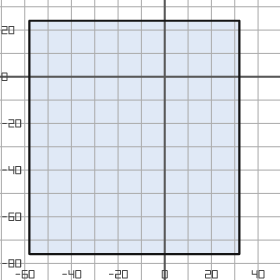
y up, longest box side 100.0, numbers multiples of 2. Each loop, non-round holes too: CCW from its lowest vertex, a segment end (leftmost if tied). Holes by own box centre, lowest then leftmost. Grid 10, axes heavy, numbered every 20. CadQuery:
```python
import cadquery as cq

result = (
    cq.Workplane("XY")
    .moveTo(-58.0, -76.0)
    .lineTo(32.0, -76.0)
    .lineTo(32.0, 24.0)
    .lineTo(-58.0, 24.0)
    .close()
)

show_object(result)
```